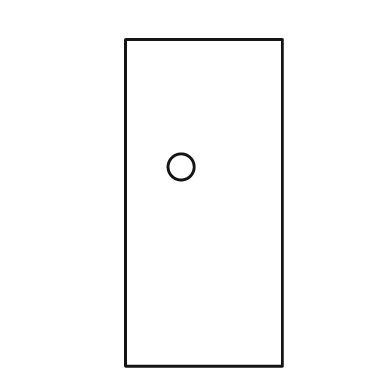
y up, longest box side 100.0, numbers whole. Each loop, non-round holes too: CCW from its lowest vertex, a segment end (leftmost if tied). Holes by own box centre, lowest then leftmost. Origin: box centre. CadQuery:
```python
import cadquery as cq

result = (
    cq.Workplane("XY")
    .moveTo(-24.0, -50.0)
    .lineTo(24.0, -50.0)
    .lineTo(24.0, 50.0)
    .lineTo(-24.0, 50.0)
    .close()
    .moveTo(-7.0, 11.0)
    .circle(4.0)
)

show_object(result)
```